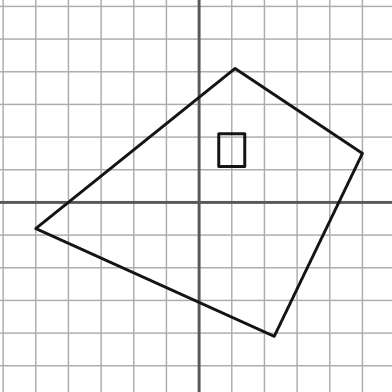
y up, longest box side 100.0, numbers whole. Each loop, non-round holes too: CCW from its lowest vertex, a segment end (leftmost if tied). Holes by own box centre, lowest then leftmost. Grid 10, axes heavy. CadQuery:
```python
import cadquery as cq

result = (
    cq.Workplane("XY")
    .moveTo(23.0, -41.0)
    .lineTo(50.0, 15.0)
    .lineTo(11.0, 41.0)
    .lineTo(-50.0, -8.0)
    .close()
    .moveTo(6.0, 11.0)
    .lineTo(14.0, 11.0)
    .lineTo(14.0, 21.0)
    .lineTo(6.0, 21.0)
    .close()
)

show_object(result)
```